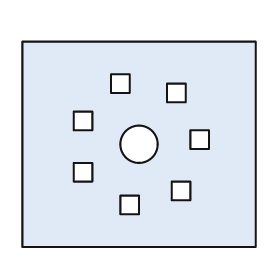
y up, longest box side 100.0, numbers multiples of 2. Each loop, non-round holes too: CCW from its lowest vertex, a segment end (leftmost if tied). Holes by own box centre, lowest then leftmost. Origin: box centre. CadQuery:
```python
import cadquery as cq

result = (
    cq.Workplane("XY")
    .moveTo(-50.0, -44.0)
    .lineTo(50.0, -44.0)
    .lineTo(50.0, 44.0)
    .lineTo(-50.0, 44.0)
    .close()
    .moveTo(-8.0, -30.0)
    .lineTo(0.0, -30.0)
    .lineTo(0.0, -22.0)
    .lineTo(-8.0, -22.0)
    .close()
    .moveTo(14.0, -24.0)
    .lineTo(22.0, -24.0)
    .lineTo(22.0, -16.0)
    .lineTo(14.0, -16.0)
    .close()
    .moveTo(-28.0, -16.0)
    .lineTo(-20.0, -16.0)
    .lineTo(-20.0, -8.0)
    .lineTo(-28.0, -8.0)
    .close()
    .moveTo(0.0, 0.0)
    .circle(8.0)
    .moveTo(22.0, -2.0)
    .lineTo(30.0, -2.0)
    .lineTo(30.0, 6.0)
    .lineTo(22.0, 6.0)
    .close()
    .moveTo(-28.0, 6.0)
    .lineTo(-20.0, 6.0)
    .lineTo(-20.0, 14.0)
    .lineTo(-28.0, 14.0)
    .close()
    .moveTo(12.0, 18.0)
    .lineTo(20.0, 18.0)
    .lineTo(20.0, 26.0)
    .lineTo(12.0, 26.0)
    .close()
    .moveTo(-12.0, 22.0)
    .lineTo(-4.0, 22.0)
    .lineTo(-4.0, 30.0)
    .lineTo(-12.0, 30.0)
    .close()
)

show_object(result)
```